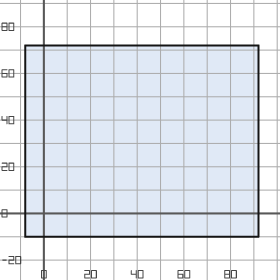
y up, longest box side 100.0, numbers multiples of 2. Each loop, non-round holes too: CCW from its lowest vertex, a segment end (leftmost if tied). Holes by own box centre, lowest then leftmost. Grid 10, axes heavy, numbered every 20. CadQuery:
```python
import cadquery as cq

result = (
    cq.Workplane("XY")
    .moveTo(-8.0, -10.0)
    .lineTo(92.0, -10.0)
    .lineTo(92.0, 72.0)
    .lineTo(-8.0, 72.0)
    .close()
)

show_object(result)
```